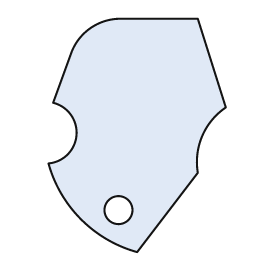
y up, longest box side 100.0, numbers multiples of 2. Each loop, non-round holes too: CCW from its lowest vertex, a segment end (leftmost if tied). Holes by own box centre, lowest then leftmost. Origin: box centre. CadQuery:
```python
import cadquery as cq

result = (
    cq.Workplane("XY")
    .moveTo(0.0, -50.0)
    .lineTo(26.0, -16.0)
    .threePointArc((28.0, 0.0), (38.0, 12.0))
    .lineTo(26.0, 50.0)
    .lineTo(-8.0, 50.0)
    .threePointArc((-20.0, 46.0), (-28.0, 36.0))
    .lineTo(-36.0, 14.0)
    .threePointArc((-26.0, 0.0), (-38.0, -12.0))
    .threePointArc((-24.0, -36.0), (0.0, -50.0))
    .close()
    .moveTo(-8.0, -32.0)
    .circle(6.0)
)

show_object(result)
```